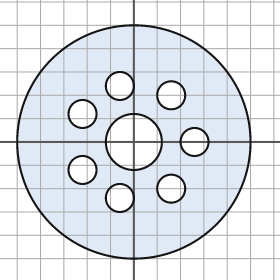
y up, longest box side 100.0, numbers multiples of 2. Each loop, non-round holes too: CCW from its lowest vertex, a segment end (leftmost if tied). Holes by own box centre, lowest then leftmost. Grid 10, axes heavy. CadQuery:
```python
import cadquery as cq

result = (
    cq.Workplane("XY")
    .moveTo(0.0, 0.0)
    .circle(50.0)
    .moveTo(-6.0, -24.0)
    .circle(6.0)
    .moveTo(16.0, -20.0)
    .circle(6.0)
    .moveTo(-22.0, -12.0)
    .circle(6.0)
    .moveTo(0.0, 0.0)
    .circle(12.0)
    .moveTo(26.0, 0.0)
    .circle(6.0)
    .moveTo(-22.0, 12.0)
    .circle(6.0)
    .moveTo(16.0, 20.0)
    .circle(6.0)
    .moveTo(-6.0, 24.0)
    .circle(6.0)
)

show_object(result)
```